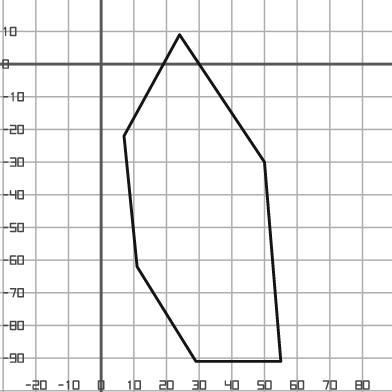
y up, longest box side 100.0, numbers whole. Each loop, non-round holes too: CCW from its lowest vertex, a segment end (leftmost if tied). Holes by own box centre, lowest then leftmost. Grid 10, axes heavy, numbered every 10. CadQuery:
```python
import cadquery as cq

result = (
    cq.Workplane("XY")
    .moveTo(29.0, -91.0)
    .lineTo(55.0, -91.0)
    .lineTo(50.0, -30.0)
    .lineTo(24.0, 9.0)
    .lineTo(7.0, -22.0)
    .lineTo(11.0, -62.0)
    .close()
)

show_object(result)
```